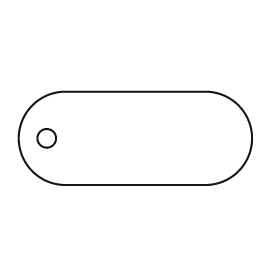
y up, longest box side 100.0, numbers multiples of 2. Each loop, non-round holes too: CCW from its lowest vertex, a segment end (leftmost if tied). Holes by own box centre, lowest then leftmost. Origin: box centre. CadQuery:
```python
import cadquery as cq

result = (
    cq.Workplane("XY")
    .moveTo(-30.0, -20.0)
    .lineTo(30.0, -20.0)
    .threePointArc((50.0, 0.0), (30.0, 20.0))
    .lineTo(-30.0, 20.0)
    .threePointArc((-50.0, 0.0), (-30.0, -20.0))
    .close()
    .moveTo(-38.0, 0.0)
    .circle(4.0)
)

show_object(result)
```